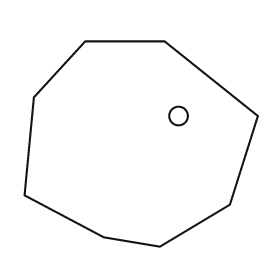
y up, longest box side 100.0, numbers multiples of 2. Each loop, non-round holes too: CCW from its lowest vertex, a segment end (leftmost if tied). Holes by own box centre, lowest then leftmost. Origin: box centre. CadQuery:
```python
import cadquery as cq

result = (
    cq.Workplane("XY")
    .moveTo(8.0, -44.0)
    .lineTo(38.0, -26.0)
    .lineTo(50.0, 12.0)
    .lineTo(10.0, 44.0)
    .lineTo(-24.0, 44.0)
    .lineTo(-46.0, 20.0)
    .lineTo(-50.0, -22.0)
    .lineTo(-16.0, -40.0)
    .close()
    .moveTo(16.0, 12.0)
    .circle(4.0)
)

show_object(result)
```